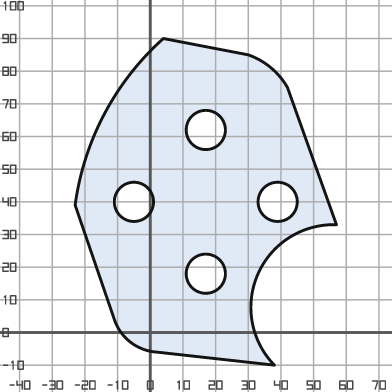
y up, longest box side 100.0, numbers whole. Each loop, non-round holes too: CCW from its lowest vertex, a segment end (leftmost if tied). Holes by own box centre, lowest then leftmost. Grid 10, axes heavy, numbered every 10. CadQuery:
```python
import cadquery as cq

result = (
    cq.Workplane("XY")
    .moveTo(38.0, -10.0)
    .threePointArc((33.0, 18.0), (57.0, 33.0))
    .lineTo(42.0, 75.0)
    .threePointArc((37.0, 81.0), (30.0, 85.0))
    .lineTo(4.0, 90.0)
    .threePointArc((-14.0, 67.0), (-23.0, 39.0))
    .lineTo(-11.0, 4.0)
    .threePointArc((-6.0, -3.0), (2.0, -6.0))
    .close()
    .moveTo(17.0, 18.0)
    .circle(6.0)
    .moveTo(-5.0, 40.0)
    .circle(6.0)
    .moveTo(39.0, 40.0)
    .circle(6.0)
    .moveTo(17.0, 62.0)
    .circle(6.0)
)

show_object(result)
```